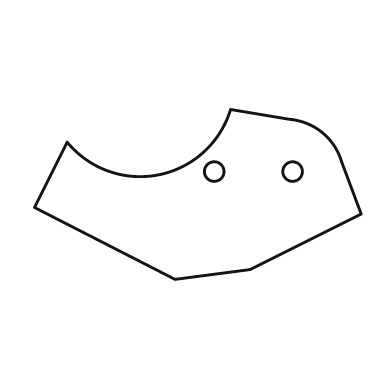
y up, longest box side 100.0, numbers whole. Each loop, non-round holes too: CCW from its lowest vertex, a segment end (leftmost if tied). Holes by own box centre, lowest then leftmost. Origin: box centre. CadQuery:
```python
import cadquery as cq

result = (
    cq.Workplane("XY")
    .moveTo(-7.0, -26.0)
    .lineTo(16.0, -23.0)
    .lineTo(50.0, -6.0)
    .lineTo(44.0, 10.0)
    .threePointArc((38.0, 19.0), (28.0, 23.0))
    .lineTo(10.0, 26.0)
    .threePointArc((-12.0, 6.0), (-40.0, 16.0))
    .lineTo(-50.0, -4.0)
    .close()
    .moveTo(5.0, 7.0)
    .circle(3.0)
    .moveTo(29.0, 7.0)
    .circle(3.0)
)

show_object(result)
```